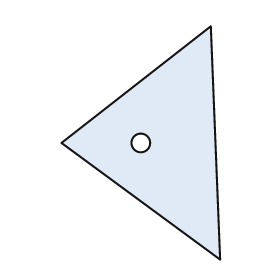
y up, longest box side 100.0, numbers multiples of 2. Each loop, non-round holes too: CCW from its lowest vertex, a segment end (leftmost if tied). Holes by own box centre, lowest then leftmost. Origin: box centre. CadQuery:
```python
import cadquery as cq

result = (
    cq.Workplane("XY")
    .moveTo(34.0, -50.0)
    .lineTo(30.0, 50.0)
    .lineTo(-34.0, 0.0)
    .close()
    .moveTo(0.0, 0.0)
    .circle(4.0)
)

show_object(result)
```